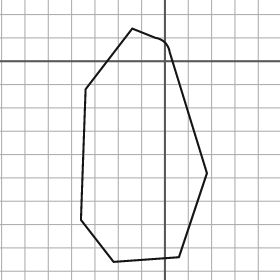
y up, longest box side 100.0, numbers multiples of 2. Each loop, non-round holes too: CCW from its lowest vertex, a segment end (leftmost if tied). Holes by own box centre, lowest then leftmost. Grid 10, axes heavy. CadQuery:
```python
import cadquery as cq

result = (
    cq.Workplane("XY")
    .moveTo(-22.0, -86.0)
    .lineTo(6.0, -84.0)
    .lineTo(18.0, -48.0)
    .lineTo(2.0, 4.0)
    .threePointArc((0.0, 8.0), (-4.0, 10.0))
    .lineTo(-14.0, 14.0)
    .lineTo(-34.0, -12.0)
    .lineTo(-36.0, -68.0)
    .close()
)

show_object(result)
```